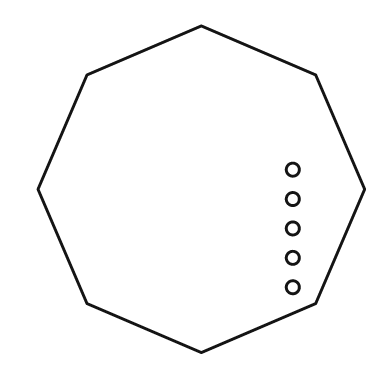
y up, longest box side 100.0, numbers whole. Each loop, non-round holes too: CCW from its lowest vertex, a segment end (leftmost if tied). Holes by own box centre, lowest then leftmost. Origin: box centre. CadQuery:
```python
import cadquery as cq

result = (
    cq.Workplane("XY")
    .moveTo(0.0, -50.0)
    .lineTo(35.0, -35.0)
    .lineTo(50.0, 0.0)
    .lineTo(35.0, 35.0)
    .lineTo(0.0, 50.0)
    .lineTo(-35.0, 35.0)
    .lineTo(-50.0, 0.0)
    .lineTo(-35.0, -35.0)
    .close()
    .moveTo(28.0, -30.0)
    .circle(2.0)
    .moveTo(28.0, -21.0)
    .circle(2.0)
    .moveTo(28.0, -12.0)
    .circle(2.0)
    .moveTo(28.0, -3.0)
    .circle(2.0)
    .moveTo(28.0, 6.0)
    .circle(2.0)
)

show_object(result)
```